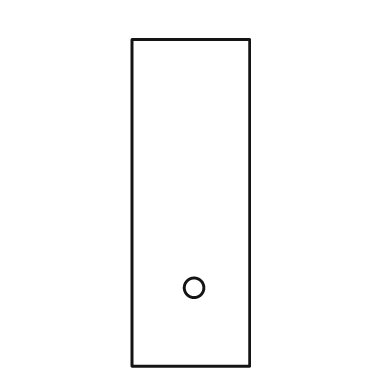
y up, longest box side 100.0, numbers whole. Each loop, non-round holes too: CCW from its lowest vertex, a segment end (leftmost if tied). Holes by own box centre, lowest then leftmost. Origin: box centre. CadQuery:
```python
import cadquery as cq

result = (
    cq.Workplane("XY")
    .moveTo(-18.0, -50.0)
    .lineTo(18.0, -50.0)
    .lineTo(18.0, 50.0)
    .lineTo(-18.0, 50.0)
    .close()
    .moveTo(1.0, -26.0)
    .circle(3.0)
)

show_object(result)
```